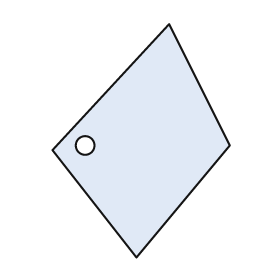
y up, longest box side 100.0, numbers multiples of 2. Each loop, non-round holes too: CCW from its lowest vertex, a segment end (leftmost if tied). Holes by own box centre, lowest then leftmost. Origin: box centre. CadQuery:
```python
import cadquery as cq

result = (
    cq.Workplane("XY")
    .moveTo(-2.0, -50.0)
    .lineTo(38.0, -2.0)
    .lineTo(12.0, 50.0)
    .lineTo(-38.0, -4.0)
    .close()
    .moveTo(-24.0, -2.0)
    .circle(4.0)
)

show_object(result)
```